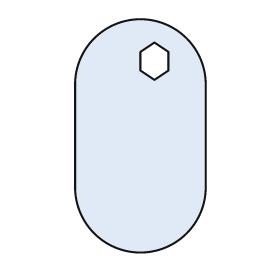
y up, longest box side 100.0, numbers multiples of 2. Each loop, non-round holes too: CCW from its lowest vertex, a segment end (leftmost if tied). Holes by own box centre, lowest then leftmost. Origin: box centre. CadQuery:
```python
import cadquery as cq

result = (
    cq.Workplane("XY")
    .moveTo(-28.0, -22.0)
    .threePointArc((0.0, -50.0), (28.0, -22.0))
    .lineTo(28.0, 22.0)
    .threePointArc((0.0, 50.0), (-28.0, 22.0))
    .close()
    .moveTo(6.0, 24.0)
    .lineTo(12.0, 28.0)
    .lineTo(12.0, 36.0)
    .lineTo(6.0, 40.0)
    .lineTo(0.0, 36.0)
    .lineTo(0.0, 28.0)
    .close()
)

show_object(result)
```